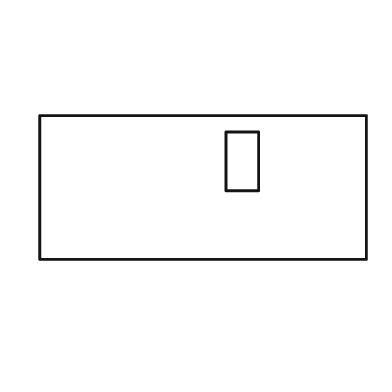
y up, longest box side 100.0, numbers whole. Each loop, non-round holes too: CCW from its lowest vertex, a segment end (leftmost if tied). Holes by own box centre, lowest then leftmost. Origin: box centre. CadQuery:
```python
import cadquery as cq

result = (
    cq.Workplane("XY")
    .moveTo(-50.0, -22.0)
    .lineTo(50.0, -22.0)
    .lineTo(50.0, 22.0)
    .lineTo(-50.0, 22.0)
    .close()
    .moveTo(7.0, -1.0)
    .lineTo(17.0, -1.0)
    .lineTo(17.0, 17.0)
    .lineTo(7.0, 17.0)
    .close()
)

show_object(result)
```